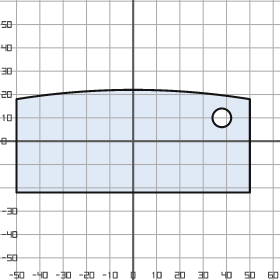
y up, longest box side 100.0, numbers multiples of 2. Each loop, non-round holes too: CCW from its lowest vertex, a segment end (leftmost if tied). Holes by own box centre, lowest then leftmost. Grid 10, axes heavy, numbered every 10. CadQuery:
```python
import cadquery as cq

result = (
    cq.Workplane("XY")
    .moveTo(-50.0, -22.0)
    .lineTo(50.0, -22.0)
    .lineTo(50.0, 18.0)
    .threePointArc((0.0, 22.0), (-50.0, 18.0))
    .close()
    .moveTo(38.0, 10.0)
    .circle(4.0)
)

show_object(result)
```